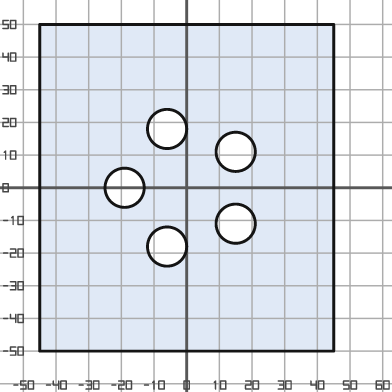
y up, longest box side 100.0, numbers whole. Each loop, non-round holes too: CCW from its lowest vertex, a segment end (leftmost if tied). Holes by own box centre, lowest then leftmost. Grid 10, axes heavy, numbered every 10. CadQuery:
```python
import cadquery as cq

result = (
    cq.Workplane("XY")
    .moveTo(-45.0, -50.0)
    .lineTo(45.0, -50.0)
    .lineTo(45.0, 50.0)
    .lineTo(-45.0, 50.0)
    .close()
    .moveTo(-6.0, -18.0)
    .circle(6.0)
    .moveTo(15.0, -11.0)
    .circle(6.0)
    .moveTo(-19.0, 0.0)
    .circle(6.0)
    .moveTo(15.0, 11.0)
    .circle(6.0)
    .moveTo(-6.0, 18.0)
    .circle(6.0)
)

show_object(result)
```